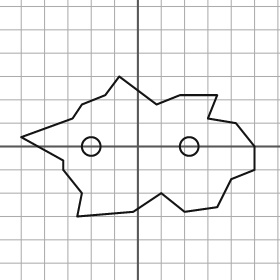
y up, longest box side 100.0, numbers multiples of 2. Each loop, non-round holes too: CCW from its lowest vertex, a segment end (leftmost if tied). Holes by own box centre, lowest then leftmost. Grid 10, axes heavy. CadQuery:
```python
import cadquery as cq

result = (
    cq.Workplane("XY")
    .moveTo(-26.0, -30.0)
    .lineTo(-2.0, -28.0)
    .lineTo(10.0, -20.0)
    .lineTo(20.0, -28.0)
    .lineTo(34.0, -26.0)
    .lineTo(40.0, -14.0)
    .lineTo(50.0, -10.0)
    .lineTo(50.0, 0.0)
    .lineTo(42.0, 10.0)
    .lineTo(30.0, 12.0)
    .lineTo(34.0, 22.0)
    .lineTo(18.0, 22.0)
    .lineTo(8.0, 18.0)
    .lineTo(-8.0, 30.0)
    .lineTo(-14.0, 22.0)
    .lineTo(-24.0, 18.0)
    .lineTo(-28.0, 12.0)
    .lineTo(-50.0, 4.0)
    .lineTo(-32.0, -6.0)
    .lineTo(-32.0, -10.0)
    .lineTo(-24.0, -20.0)
    .close()
    .moveTo(-20.0, 0.0)
    .circle(4.0)
    .moveTo(22.0, 0.0)
    .circle(4.0)
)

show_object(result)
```